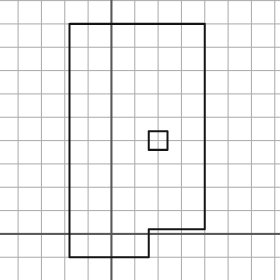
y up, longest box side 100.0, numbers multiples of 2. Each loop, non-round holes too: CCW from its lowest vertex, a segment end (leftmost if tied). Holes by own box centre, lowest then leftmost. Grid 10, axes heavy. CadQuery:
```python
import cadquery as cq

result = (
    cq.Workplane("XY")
    .moveTo(-18.0, -10.0)
    .lineTo(16.0, -10.0)
    .lineTo(16.0, 2.0)
    .lineTo(40.0, 2.0)
    .lineTo(40.0, 90.0)
    .lineTo(-18.0, 90.0)
    .close()
    .moveTo(16.0, 36.0)
    .lineTo(24.0, 36.0)
    .lineTo(24.0, 44.0)
    .lineTo(16.0, 44.0)
    .close()
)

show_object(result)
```